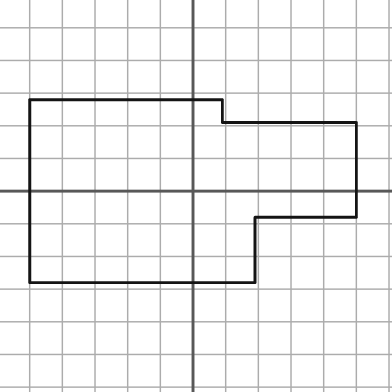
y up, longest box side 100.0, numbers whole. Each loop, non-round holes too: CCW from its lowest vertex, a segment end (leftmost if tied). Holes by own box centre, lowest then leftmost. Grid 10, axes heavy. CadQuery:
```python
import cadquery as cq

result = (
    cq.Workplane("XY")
    .moveTo(-50.0, -28.0)
    .lineTo(19.0, -28.0)
    .lineTo(19.0, -8.0)
    .lineTo(50.0, -8.0)
    .lineTo(50.0, 21.0)
    .lineTo(9.0, 21.0)
    .lineTo(9.0, 28.0)
    .lineTo(-50.0, 28.0)
    .close()
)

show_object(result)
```